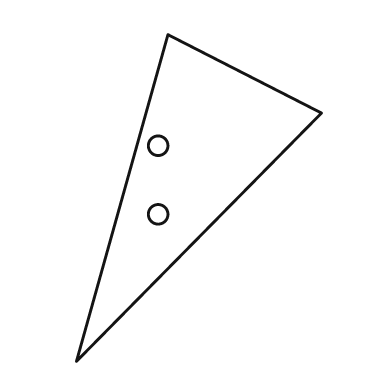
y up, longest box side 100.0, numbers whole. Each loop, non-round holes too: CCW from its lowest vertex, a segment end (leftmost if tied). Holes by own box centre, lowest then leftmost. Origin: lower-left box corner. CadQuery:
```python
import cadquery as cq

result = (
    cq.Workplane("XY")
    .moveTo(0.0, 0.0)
    .lineTo(75.0, 76.0)
    .lineTo(28.0, 100.0)
    .close()
    .moveTo(25.0, 45.0)
    .circle(3.0)
    .moveTo(25.0, 66.0)
    .circle(3.0)
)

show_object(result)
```